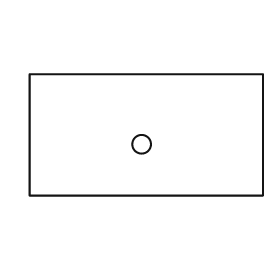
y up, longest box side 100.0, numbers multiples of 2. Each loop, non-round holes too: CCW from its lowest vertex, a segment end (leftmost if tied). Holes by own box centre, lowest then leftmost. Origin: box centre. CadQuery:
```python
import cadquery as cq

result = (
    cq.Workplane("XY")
    .moveTo(-50.0, -26.0)
    .lineTo(50.0, -26.0)
    .lineTo(50.0, 26.0)
    .lineTo(-50.0, 26.0)
    .close()
    .moveTo(-2.0, -4.0)
    .circle(4.0)
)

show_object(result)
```